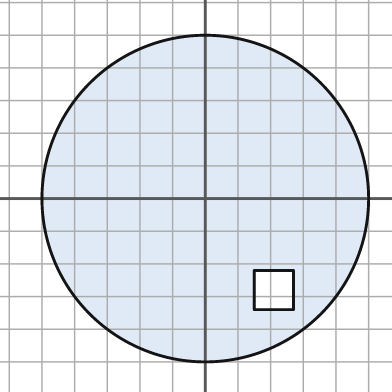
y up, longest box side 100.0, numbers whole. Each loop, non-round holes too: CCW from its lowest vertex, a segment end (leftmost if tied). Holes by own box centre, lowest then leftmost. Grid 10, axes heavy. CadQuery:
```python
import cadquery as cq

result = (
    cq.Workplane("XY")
    .moveTo(0.0, 0.0)
    .circle(50.0)
    .moveTo(15.0, -34.0)
    .lineTo(27.0, -34.0)
    .lineTo(27.0, -22.0)
    .lineTo(15.0, -22.0)
    .close()
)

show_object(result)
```